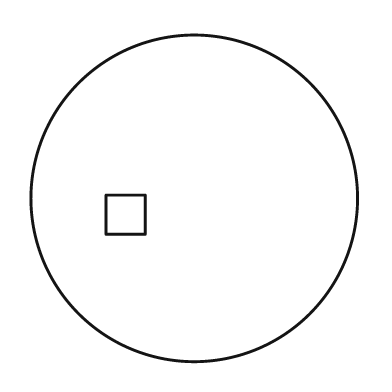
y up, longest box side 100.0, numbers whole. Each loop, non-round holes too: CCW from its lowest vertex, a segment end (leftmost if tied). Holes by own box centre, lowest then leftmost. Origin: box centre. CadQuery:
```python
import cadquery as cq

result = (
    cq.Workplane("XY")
    .moveTo(0.0, 0.0)
    .circle(50.0)
    .moveTo(-27.0, -11.0)
    .lineTo(-15.0, -11.0)
    .lineTo(-15.0, 1.0)
    .lineTo(-27.0, 1.0)
    .close()
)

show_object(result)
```